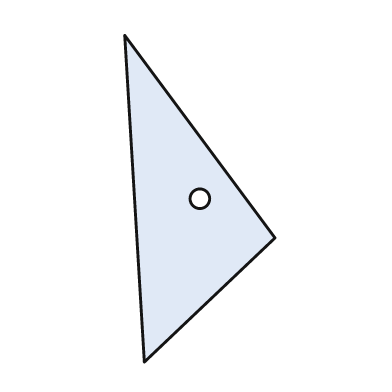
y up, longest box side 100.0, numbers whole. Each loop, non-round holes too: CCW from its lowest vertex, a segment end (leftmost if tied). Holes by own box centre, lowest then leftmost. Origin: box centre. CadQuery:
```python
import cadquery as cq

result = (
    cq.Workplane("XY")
    .moveTo(-17.0, -50.0)
    .lineTo(23.0, -12.0)
    .lineTo(-23.0, 50.0)
    .close()
    .moveTo(0.0, 0.0)
    .circle(3.0)
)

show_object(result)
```